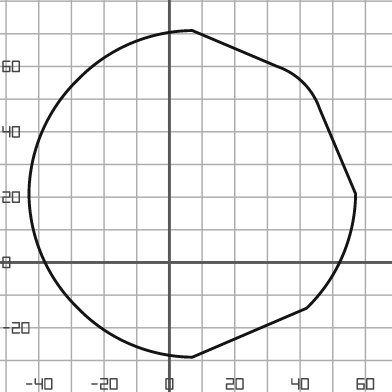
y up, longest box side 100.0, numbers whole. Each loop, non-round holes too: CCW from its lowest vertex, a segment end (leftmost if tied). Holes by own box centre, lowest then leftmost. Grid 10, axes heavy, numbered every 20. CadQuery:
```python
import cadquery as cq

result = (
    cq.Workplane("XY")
    .moveTo(7.0, -29.0)
    .lineTo(42.0, -14.0)
    .threePointArc((53.0, 2.0), (57.0, 21.0))
    .lineTo(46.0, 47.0)
    .threePointArc((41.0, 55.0), (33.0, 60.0))
    .lineTo(7.0, 71.0)
    .threePointArc((-12.0, 67.0), (-28.0, 56.0))
    .threePointArc((-39.0, 40.0), (-43.0, 21.0))
    .threePointArc((-39.0, 2.0), (-28.0, -14.0))
    .threePointArc((-12.0, -25.0), (7.0, -29.0))
    .close()
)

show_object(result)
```